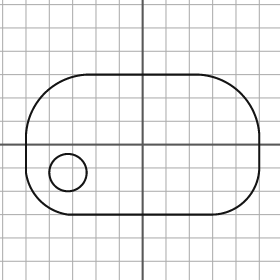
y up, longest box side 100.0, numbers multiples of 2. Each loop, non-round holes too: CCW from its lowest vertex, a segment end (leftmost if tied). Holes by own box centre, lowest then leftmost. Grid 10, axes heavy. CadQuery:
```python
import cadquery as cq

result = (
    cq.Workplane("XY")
    .moveTo(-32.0, -30.0)
    .lineTo(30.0, -30.0)
    .threePointArc((44.0, -24.0), (50.0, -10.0))
    .lineTo(50.0, 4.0)
    .threePointArc((42.0, 22.0), (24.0, 30.0))
    .lineTo(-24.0, 30.0)
    .threePointArc((-42.0, 22.0), (-50.0, 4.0))
    .lineTo(-50.0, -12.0)
    .threePointArc((-44.0, -24.0), (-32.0, -30.0))
    .close()
    .moveTo(-32.0, -12.0)
    .circle(8.0)
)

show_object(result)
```